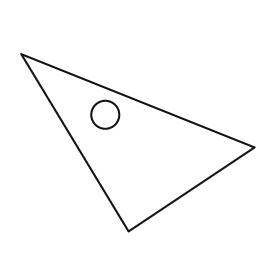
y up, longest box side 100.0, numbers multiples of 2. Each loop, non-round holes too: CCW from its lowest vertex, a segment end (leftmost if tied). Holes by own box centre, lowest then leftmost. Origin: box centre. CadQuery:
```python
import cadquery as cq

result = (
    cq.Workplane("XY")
    .moveTo(-4.0, -38.0)
    .lineTo(50.0, -2.0)
    .lineTo(-50.0, 38.0)
    .close()
    .moveTo(-14.0, 12.0)
    .circle(6.0)
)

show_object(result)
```